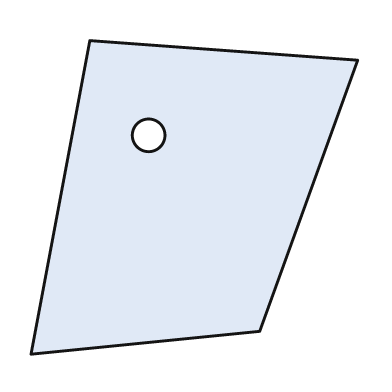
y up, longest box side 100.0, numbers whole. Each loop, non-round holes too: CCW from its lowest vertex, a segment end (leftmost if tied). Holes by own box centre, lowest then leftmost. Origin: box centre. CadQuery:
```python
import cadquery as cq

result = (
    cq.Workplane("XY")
    .moveTo(-50.0, -48.0)
    .lineTo(20.0, -41.0)
    .lineTo(50.0, 42.0)
    .lineTo(-32.0, 48.0)
    .close()
    .moveTo(-14.0, 19.0)
    .circle(5.0)
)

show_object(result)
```